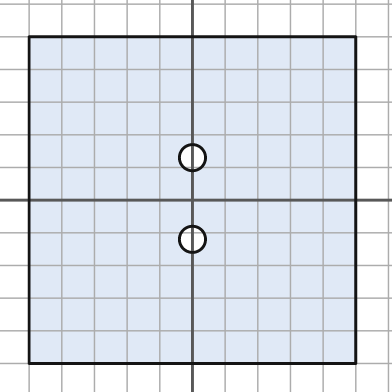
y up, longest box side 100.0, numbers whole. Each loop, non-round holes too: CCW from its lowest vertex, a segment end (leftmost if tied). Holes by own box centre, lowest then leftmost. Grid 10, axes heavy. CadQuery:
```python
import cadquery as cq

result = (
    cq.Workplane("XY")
    .moveTo(-50.0, -50.0)
    .lineTo(50.0, -50.0)
    .lineTo(50.0, 50.0)
    .lineTo(-50.0, 50.0)
    .close()
    .moveTo(0.0, -12.0)
    .circle(4.0)
    .moveTo(0.0, 13.0)
    .circle(4.0)
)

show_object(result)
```